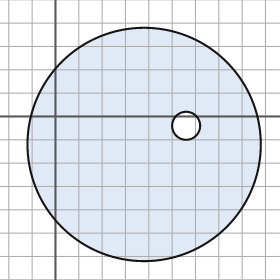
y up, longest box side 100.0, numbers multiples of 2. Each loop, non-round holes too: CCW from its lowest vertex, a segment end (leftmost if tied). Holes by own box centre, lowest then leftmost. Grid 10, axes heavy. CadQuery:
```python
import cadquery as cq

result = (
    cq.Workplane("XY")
    .moveTo(38.0, -12.0)
    .circle(50.0)
    .moveTo(56.0, -4.0)
    .circle(6.0)
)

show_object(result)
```